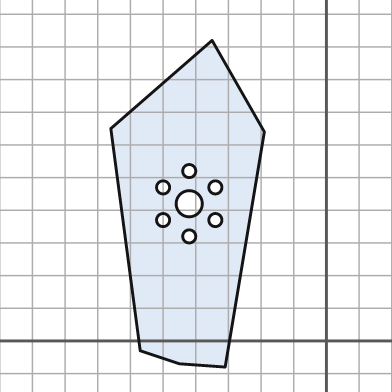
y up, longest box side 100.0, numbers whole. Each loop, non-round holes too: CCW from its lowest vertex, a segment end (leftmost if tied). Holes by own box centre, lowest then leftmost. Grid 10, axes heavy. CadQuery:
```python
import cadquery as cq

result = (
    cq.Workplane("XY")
    .moveTo(-31.0, -8.0)
    .lineTo(-19.0, 64.0)
    .lineTo(-35.0, 92.0)
    .lineTo(-66.0, 65.0)
    .lineTo(-57.0, -3.0)
    .lineTo(-45.0, -7.0)
    .close()
    .moveTo(-42.0, 32.0)
    .circle(2.0)
    .moveTo(-50.0, 37.0)
    .circle(2.0)
    .moveTo(-34.0, 37.0)
    .circle(2.0)
    .moveTo(-42.0, 42.0)
    .circle(4.0)
    .moveTo(-50.0, 47.0)
    .circle(2.0)
    .moveTo(-34.0, 47.0)
    .circle(2.0)
    .moveTo(-42.0, 52.0)
    .circle(2.0)
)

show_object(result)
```